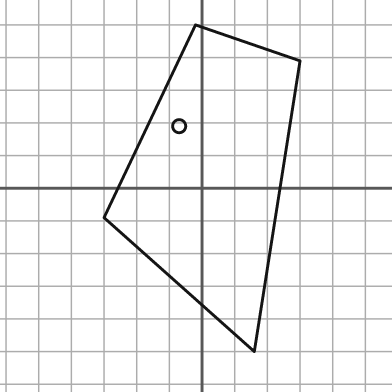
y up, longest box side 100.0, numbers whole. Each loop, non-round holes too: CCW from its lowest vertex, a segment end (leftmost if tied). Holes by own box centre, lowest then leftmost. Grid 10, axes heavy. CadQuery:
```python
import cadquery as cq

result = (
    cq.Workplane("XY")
    .moveTo(16.0, -50.0)
    .lineTo(30.0, 39.0)
    .lineTo(-2.0, 50.0)
    .lineTo(-30.0, -9.0)
    .close()
    .moveTo(-7.0, 19.0)
    .circle(2.0)
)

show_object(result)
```